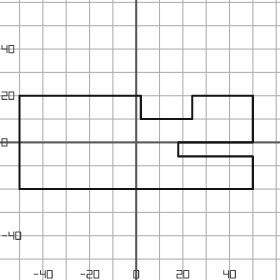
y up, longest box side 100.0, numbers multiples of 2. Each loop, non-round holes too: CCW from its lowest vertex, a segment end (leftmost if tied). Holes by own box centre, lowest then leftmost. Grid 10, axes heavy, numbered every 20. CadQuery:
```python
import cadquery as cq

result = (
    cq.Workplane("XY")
    .moveTo(-50.0, -20.0)
    .lineTo(50.0, -20.0)
    .lineTo(50.0, -6.0)
    .lineTo(18.0, -6.0)
    .lineTo(18.0, 0.0)
    .lineTo(50.0, 0.0)
    .lineTo(50.0, 20.0)
    .lineTo(24.0, 20.0)
    .lineTo(24.0, 10.0)
    .lineTo(2.0, 10.0)
    .lineTo(2.0, 20.0)
    .lineTo(-50.0, 20.0)
    .close()
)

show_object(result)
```